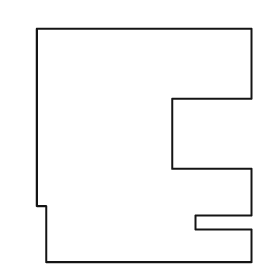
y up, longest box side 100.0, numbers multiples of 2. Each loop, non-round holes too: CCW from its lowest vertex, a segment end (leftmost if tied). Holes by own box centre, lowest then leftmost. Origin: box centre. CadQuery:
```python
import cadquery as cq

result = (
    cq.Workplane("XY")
    .moveTo(-42.0, -50.0)
    .lineTo(46.0, -50.0)
    .lineTo(46.0, -36.0)
    .lineTo(22.0, -36.0)
    .lineTo(22.0, -30.0)
    .lineTo(46.0, -30.0)
    .lineTo(46.0, -10.0)
    .lineTo(12.0, -10.0)
    .lineTo(12.0, 20.0)
    .lineTo(46.0, 20.0)
    .lineTo(46.0, 50.0)
    .lineTo(-46.0, 50.0)
    .lineTo(-46.0, -26.0)
    .lineTo(-42.0, -26.0)
    .close()
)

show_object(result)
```